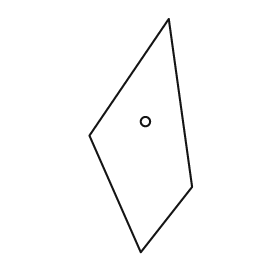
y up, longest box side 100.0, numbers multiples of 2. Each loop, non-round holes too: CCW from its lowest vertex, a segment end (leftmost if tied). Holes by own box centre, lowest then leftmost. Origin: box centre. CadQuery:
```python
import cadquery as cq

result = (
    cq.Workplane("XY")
    .moveTo(0.0, -50.0)
    .lineTo(22.0, -22.0)
    .lineTo(12.0, 50.0)
    .lineTo(-22.0, 0.0)
    .close()
    .moveTo(2.0, 6.0)
    .circle(2.0)
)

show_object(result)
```